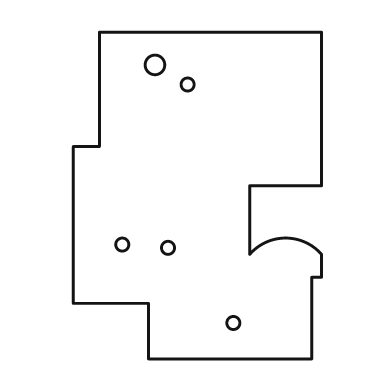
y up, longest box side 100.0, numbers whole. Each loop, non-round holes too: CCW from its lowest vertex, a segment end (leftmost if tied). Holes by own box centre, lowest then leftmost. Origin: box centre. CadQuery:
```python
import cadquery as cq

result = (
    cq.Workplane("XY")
    .moveTo(-15.0, -50.0)
    .lineTo(35.0, -50.0)
    .lineTo(35.0, -25.0)
    .lineTo(38.0, -25.0)
    .lineTo(38.0, -18.0)
    .threePointArc((27.0, -13.0), (16.0, -18.0))
    .lineTo(16.0, 3.0)
    .lineTo(38.0, 3.0)
    .lineTo(38.0, 50.0)
    .lineTo(-30.0, 50.0)
    .lineTo(-30.0, 15.0)
    .lineTo(-38.0, 15.0)
    .lineTo(-38.0, -33.0)
    .lineTo(-15.0, -33.0)
    .close()
    .moveTo(11.0, -39.0)
    .circle(2.0)
    .moveTo(-9.0, -16.0)
    .circle(2.0)
    .moveTo(-23.0, -15.0)
    .circle(2.0)
    .moveTo(-3.0, 34.0)
    .circle(2.0)
    .moveTo(-13.0, 40.0)
    .circle(3.0)
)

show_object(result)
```